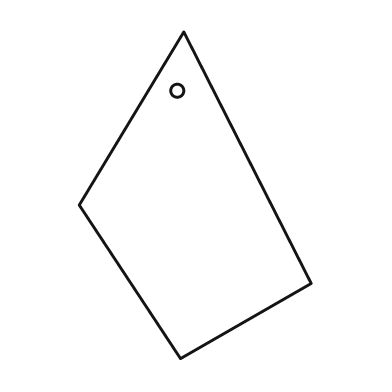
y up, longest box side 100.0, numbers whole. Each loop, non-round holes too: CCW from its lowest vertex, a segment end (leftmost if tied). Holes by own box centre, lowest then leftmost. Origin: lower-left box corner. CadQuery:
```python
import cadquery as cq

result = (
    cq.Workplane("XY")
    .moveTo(31.0, 0.0)
    .lineTo(71.0, 23.0)
    .lineTo(32.0, 100.0)
    .lineTo(0.0, 47.0)
    .close()
    .moveTo(30.0, 82.0)
    .circle(2.0)
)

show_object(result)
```